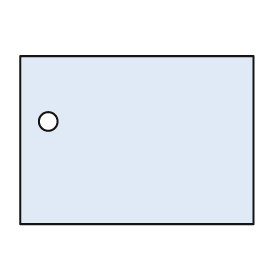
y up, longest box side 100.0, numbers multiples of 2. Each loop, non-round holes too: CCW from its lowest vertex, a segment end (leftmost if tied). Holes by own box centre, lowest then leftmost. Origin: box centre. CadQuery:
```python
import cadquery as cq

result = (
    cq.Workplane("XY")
    .moveTo(-50.0, -36.0)
    .lineTo(50.0, -36.0)
    .lineTo(50.0, 36.0)
    .lineTo(-50.0, 36.0)
    .close()
    .moveTo(-38.0, 8.0)
    .circle(4.0)
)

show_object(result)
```